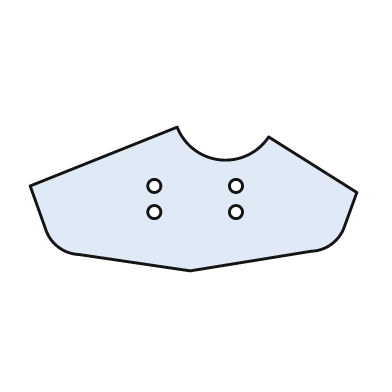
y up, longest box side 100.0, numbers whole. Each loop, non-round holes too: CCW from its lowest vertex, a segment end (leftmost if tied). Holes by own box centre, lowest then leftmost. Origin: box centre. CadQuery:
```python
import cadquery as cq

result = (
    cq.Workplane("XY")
    .moveTo(-1.0, -22.0)
    .lineTo(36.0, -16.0)
    .threePointArc((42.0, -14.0), (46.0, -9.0))
    .lineTo(50.0, 2.0)
    .lineTo(23.0, 19.0)
    .threePointArc((8.0, 12.0), (-5.0, 22.0))
    .lineTo(-50.0, 4.0)
    .lineTo(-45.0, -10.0)
    .threePointArc((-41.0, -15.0), (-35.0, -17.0))
    .close()
    .moveTo(-12.0, -4.0)
    .circle(2.0)
    .moveTo(13.0, -4.0)
    .circle(2.0)
    .moveTo(-12.0, 4.0)
    .circle(2.0)
    .moveTo(13.0, 4.0)
    .circle(2.0)
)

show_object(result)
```